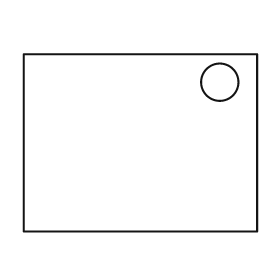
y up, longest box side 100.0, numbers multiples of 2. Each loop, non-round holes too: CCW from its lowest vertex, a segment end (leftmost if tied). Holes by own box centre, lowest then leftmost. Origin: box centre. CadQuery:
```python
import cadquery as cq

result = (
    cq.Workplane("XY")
    .moveTo(-50.0, -38.0)
    .lineTo(50.0, -38.0)
    .lineTo(50.0, 38.0)
    .lineTo(-50.0, 38.0)
    .close()
    .moveTo(34.0, 26.0)
    .circle(8.0)
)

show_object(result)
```